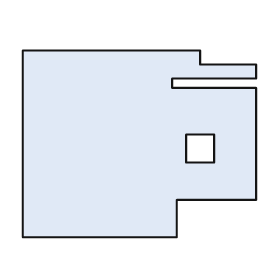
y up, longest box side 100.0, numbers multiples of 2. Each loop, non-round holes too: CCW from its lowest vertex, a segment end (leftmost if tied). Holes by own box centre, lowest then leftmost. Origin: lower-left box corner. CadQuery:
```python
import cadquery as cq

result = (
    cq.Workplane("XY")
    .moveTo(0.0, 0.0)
    .lineTo(66.0, 0.0)
    .lineTo(66.0, 16.0)
    .lineTo(100.0, 16.0)
    .lineTo(100.0, 64.0)
    .lineTo(64.0, 64.0)
    .lineTo(64.0, 68.0)
    .lineTo(100.0, 68.0)
    .lineTo(100.0, 74.0)
    .lineTo(76.0, 74.0)
    .lineTo(76.0, 80.0)
    .lineTo(0.0, 80.0)
    .close()
    .moveTo(70.0, 32.0)
    .lineTo(82.0, 32.0)
    .lineTo(82.0, 44.0)
    .lineTo(70.0, 44.0)
    .close()
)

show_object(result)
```